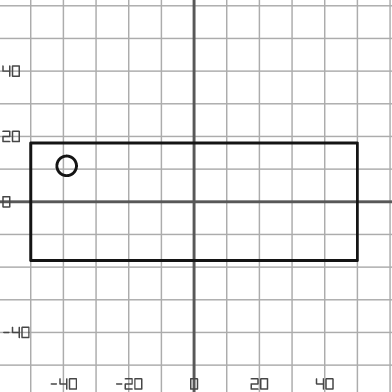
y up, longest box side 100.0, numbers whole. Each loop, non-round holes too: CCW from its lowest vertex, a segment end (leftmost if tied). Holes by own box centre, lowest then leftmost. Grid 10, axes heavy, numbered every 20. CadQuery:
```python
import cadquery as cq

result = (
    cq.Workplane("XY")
    .moveTo(-50.0, -18.0)
    .lineTo(50.0, -18.0)
    .lineTo(50.0, 18.0)
    .lineTo(-50.0, 18.0)
    .close()
    .moveTo(-39.0, 11.0)
    .circle(3.0)
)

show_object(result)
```